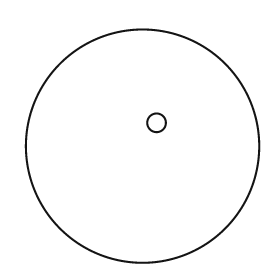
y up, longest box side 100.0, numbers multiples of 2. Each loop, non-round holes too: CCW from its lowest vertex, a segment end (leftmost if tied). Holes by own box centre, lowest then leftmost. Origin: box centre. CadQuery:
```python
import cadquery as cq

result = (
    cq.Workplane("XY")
    .moveTo(0.0, 0.0)
    .circle(50.0)
    .moveTo(6.0, 10.0)
    .circle(4.0)
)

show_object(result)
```